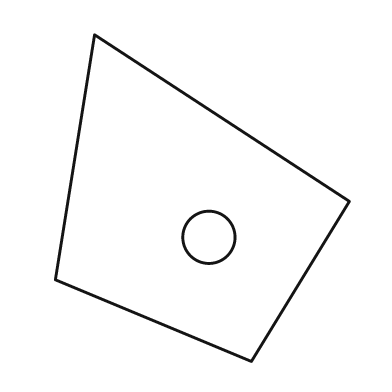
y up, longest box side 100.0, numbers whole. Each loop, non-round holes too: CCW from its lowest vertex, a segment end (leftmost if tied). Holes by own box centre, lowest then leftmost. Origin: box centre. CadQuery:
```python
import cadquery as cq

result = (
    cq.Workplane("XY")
    .moveTo(15.0, -50.0)
    .lineTo(45.0, -1.0)
    .lineTo(-33.0, 50.0)
    .lineTo(-45.0, -25.0)
    .close()
    .moveTo(2.0, -12.0)
    .circle(8.0)
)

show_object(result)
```